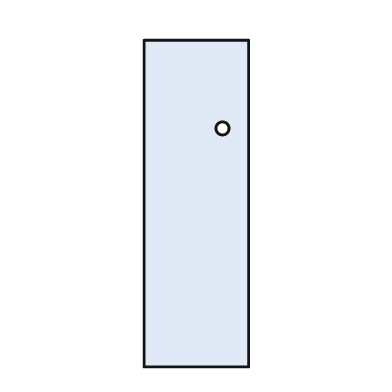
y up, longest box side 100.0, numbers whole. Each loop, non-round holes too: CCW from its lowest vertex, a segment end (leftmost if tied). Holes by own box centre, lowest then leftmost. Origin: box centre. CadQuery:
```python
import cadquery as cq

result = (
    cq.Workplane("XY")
    .moveTo(-16.0, -50.0)
    .lineTo(16.0, -50.0)
    .lineTo(16.0, 50.0)
    .lineTo(-16.0, 50.0)
    .close()
    .moveTo(8.0, 23.0)
    .circle(2.0)
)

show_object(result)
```